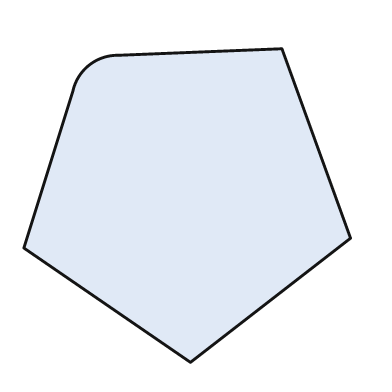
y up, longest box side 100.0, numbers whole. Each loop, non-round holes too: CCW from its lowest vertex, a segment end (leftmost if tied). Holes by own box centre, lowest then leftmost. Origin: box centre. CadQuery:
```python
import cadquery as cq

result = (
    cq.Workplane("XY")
    .moveTo(1.0, -48.0)
    .lineTo(50.0, -10.0)
    .lineTo(29.0, 48.0)
    .lineTo(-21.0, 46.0)
    .threePointArc((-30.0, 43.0), (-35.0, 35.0))
    .lineTo(-50.0, -13.0)
    .close()
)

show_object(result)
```